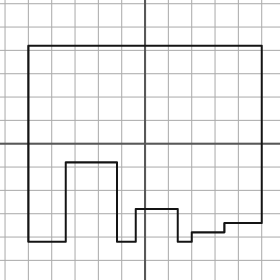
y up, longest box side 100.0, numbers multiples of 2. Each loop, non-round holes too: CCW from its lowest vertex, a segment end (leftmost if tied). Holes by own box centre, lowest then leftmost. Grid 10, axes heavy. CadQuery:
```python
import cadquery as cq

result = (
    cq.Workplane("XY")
    .moveTo(-50.0, -42.0)
    .lineTo(-34.0, -42.0)
    .lineTo(-34.0, -8.0)
    .lineTo(-12.0, -8.0)
    .lineTo(-12.0, -42.0)
    .lineTo(-4.0, -42.0)
    .lineTo(-4.0, -28.0)
    .lineTo(14.0, -28.0)
    .lineTo(14.0, -42.0)
    .lineTo(20.0, -42.0)
    .lineTo(20.0, -38.0)
    .lineTo(34.0, -38.0)
    .lineTo(34.0, -34.0)
    .lineTo(50.0, -34.0)
    .lineTo(50.0, 42.0)
    .lineTo(-50.0, 42.0)
    .close()
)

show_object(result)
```